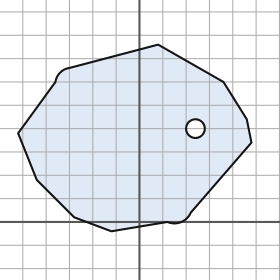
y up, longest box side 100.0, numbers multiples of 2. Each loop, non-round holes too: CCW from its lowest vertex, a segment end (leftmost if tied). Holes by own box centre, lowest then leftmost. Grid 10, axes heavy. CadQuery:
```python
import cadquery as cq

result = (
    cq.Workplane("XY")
    .moveTo(-12.0, -4.0)
    .lineTo(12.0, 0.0)
    .threePointArc((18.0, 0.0), (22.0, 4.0))
    .lineTo(48.0, 34.0)
    .lineTo(46.0, 44.0)
    .lineTo(36.0, 60.0)
    .lineTo(8.0, 76.0)
    .lineTo(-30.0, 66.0)
    .threePointArc((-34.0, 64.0), (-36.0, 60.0))
    .lineTo(-52.0, 38.0)
    .lineTo(-44.0, 18.0)
    .lineTo(-28.0, 2.0)
    .close()
    .moveTo(24.0, 40.0)
    .circle(4.0)
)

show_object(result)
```